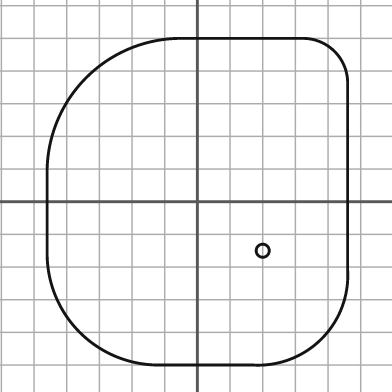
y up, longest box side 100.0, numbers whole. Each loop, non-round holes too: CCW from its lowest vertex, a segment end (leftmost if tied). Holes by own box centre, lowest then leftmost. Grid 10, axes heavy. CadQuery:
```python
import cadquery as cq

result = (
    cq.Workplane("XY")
    .moveTo(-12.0, -50.0)
    .lineTo(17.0, -50.0)
    .threePointArc((38.0, -42.0), (46.0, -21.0))
    .lineTo(46.0, 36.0)
    .threePointArc((42.0, 46.0), (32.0, 50.0))
    .lineTo(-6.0, 50.0)
    .threePointArc((-34.0, 38.0), (-46.0, 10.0))
    .lineTo(-46.0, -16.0)
    .threePointArc((-36.0, -40.0), (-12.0, -50.0))
    .close()
    .moveTo(20.0, -15.0)
    .circle(2.0)
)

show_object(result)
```